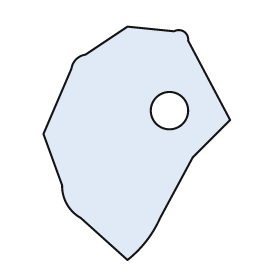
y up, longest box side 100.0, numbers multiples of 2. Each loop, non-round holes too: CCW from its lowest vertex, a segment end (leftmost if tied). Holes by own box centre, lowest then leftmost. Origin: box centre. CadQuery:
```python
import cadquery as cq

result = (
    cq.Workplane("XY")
    .moveTo(-4.0, -50.0)
    .threePointArc((4.0, -42.0), (10.0, -32.0))
    .lineTo(24.0, -6.0)
    .lineTo(40.0, 10.0)
    .lineTo(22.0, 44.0)
    .threePointArc((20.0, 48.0), (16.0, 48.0))
    .lineTo(-4.0, 50.0)
    .lineTo(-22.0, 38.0)
    .threePointArc((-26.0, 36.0), (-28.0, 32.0))
    .lineTo(-40.0, 4.0)
    .lineTo(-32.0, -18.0)
    .threePointArc((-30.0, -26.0), (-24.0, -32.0))
    .close()
    .moveTo(14.0, 14.0)
    .circle(8.0)
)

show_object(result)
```